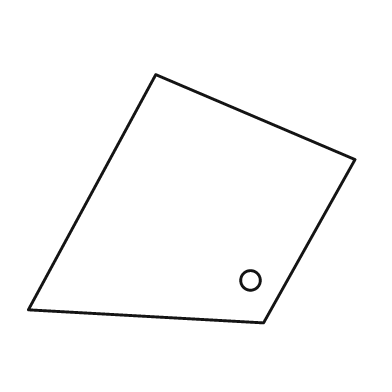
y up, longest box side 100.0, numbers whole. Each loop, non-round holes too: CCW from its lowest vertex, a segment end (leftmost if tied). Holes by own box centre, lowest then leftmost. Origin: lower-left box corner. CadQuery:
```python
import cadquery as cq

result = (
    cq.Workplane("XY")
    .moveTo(72.0, 0.0)
    .lineTo(100.0, 50.0)
    .lineTo(39.0, 76.0)
    .lineTo(0.0, 4.0)
    .close()
    .moveTo(68.0, 13.0)
    .circle(3.0)
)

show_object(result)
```